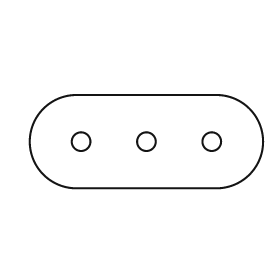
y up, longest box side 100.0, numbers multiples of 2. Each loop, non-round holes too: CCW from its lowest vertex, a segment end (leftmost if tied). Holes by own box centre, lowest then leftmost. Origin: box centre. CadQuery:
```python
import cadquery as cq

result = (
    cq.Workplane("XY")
    .moveTo(-30.0, -20.0)
    .lineTo(30.0, -20.0)
    .threePointArc((50.0, 0.0), (30.0, 20.0))
    .lineTo(-30.0, 20.0)
    .threePointArc((-50.0, 0.0), (-30.0, -20.0))
    .close()
    .moveTo(-28.0, 0.0)
    .circle(4.0)
    .moveTo(0.0, 0.0)
    .circle(4.0)
    .moveTo(28.0, 0.0)
    .circle(4.0)
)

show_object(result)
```